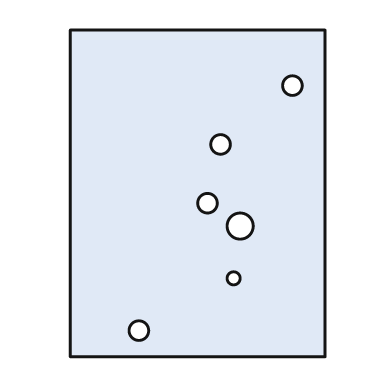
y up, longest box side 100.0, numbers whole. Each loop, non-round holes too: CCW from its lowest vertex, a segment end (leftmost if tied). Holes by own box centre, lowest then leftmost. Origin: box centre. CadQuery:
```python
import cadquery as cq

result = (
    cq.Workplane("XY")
    .moveTo(-39.0, -50.0)
    .lineTo(39.0, -50.0)
    .lineTo(39.0, 50.0)
    .lineTo(-39.0, 50.0)
    .close()
    .moveTo(-18.0, -42.0)
    .circle(3.0)
    .moveTo(11.0, -26.0)
    .circle(2.0)
    .moveTo(13.0, -10.0)
    .circle(4.0)
    .moveTo(3.0, -3.0)
    .circle(3.0)
    .moveTo(7.0, 15.0)
    .circle(3.0)
    .moveTo(29.0, 33.0)
    .circle(3.0)
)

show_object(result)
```